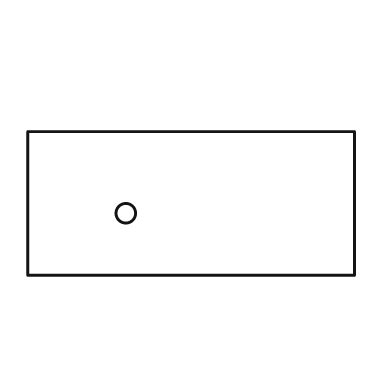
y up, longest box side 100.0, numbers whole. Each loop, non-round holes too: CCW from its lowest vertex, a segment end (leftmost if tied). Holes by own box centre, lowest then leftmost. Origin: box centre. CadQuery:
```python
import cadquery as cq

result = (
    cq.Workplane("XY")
    .moveTo(-50.0, -22.0)
    .lineTo(50.0, -22.0)
    .lineTo(50.0, 22.0)
    .lineTo(-50.0, 22.0)
    .close()
    .moveTo(-20.0, -3.0)
    .circle(3.0)
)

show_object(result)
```